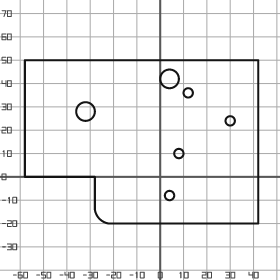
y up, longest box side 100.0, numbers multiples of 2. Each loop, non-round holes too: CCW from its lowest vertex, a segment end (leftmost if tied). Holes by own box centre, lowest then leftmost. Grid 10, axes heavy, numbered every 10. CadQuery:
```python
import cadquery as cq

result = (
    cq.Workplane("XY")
    .moveTo(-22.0, -20.0)
    .lineTo(42.0, -20.0)
    .lineTo(42.0, 50.0)
    .lineTo(-58.0, 50.0)
    .lineTo(-58.0, 0.0)
    .lineTo(-28.0, 0.0)
    .lineTo(-28.0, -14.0)
    .threePointArc((-26.0, -18.0), (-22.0, -20.0))
    .close()
    .moveTo(4.0, -8.0)
    .circle(2.0)
    .moveTo(8.0, 10.0)
    .circle(2.0)
    .moveTo(30.0, 24.0)
    .circle(2.0)
    .moveTo(-32.0, 28.0)
    .circle(4.0)
    .moveTo(12.0, 36.0)
    .circle(2.0)
    .moveTo(4.0, 42.0)
    .circle(4.0)
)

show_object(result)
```